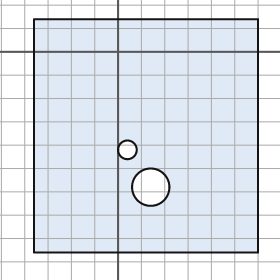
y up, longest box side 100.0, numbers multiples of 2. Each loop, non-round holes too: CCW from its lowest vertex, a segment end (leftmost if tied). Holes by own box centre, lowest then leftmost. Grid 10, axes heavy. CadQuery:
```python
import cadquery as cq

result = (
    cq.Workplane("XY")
    .moveTo(-36.0, -86.0)
    .lineTo(60.0, -86.0)
    .lineTo(60.0, 14.0)
    .lineTo(-36.0, 14.0)
    .close()
    .moveTo(14.0, -58.0)
    .circle(8.0)
    .moveTo(4.0, -42.0)
    .circle(4.0)
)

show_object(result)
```